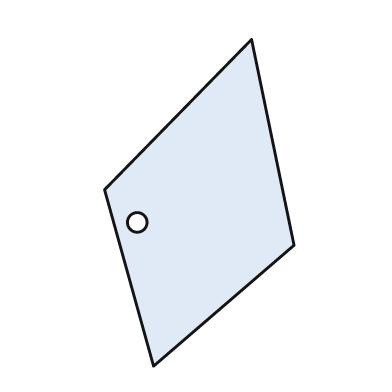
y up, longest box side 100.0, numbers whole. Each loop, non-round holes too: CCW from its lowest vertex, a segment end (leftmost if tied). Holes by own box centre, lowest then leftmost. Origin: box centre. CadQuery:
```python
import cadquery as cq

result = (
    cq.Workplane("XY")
    .moveTo(-14.0, -50.0)
    .lineTo(29.0, -13.0)
    .lineTo(16.0, 50.0)
    .lineTo(-29.0, 4.0)
    .close()
    .moveTo(-19.0, -6.0)
    .circle(3.0)
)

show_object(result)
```